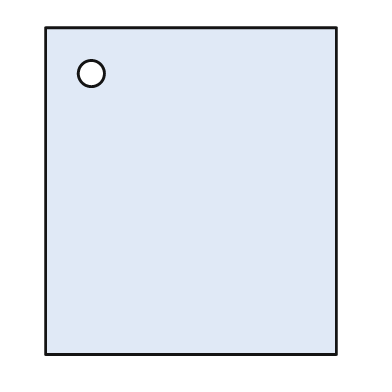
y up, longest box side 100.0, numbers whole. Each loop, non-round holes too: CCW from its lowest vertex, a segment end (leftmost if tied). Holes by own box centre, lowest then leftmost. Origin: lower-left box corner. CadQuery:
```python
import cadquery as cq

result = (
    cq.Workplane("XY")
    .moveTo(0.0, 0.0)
    .lineTo(89.0, 0.0)
    .lineTo(89.0, 100.0)
    .lineTo(0.0, 100.0)
    .close()
    .moveTo(14.0, 86.0)
    .circle(4.0)
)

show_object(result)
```